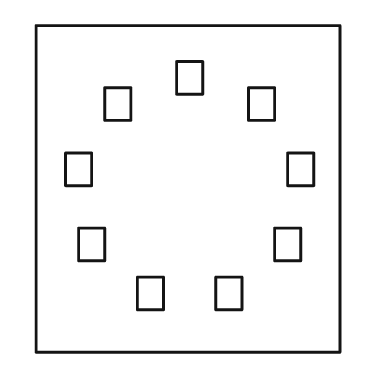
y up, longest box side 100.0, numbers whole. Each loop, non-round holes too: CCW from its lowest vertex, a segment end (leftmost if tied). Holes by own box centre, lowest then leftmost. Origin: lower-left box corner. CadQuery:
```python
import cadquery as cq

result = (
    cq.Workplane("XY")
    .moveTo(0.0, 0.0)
    .lineTo(93.0, 0.0)
    .lineTo(93.0, 100.0)
    .lineTo(0.0, 100.0)
    .close()
    .moveTo(31.0, 13.0)
    .lineTo(39.0, 13.0)
    .lineTo(39.0, 23.0)
    .lineTo(31.0, 23.0)
    .close()
    .moveTo(55.0, 13.0)
    .lineTo(63.0, 13.0)
    .lineTo(63.0, 23.0)
    .lineTo(55.0, 23.0)
    .close()
    .moveTo(13.0, 28.0)
    .lineTo(21.0, 28.0)
    .lineTo(21.0, 38.0)
    .lineTo(13.0, 38.0)
    .close()
    .moveTo(73.0, 28.0)
    .lineTo(81.0, 28.0)
    .lineTo(81.0, 38.0)
    .lineTo(73.0, 38.0)
    .close()
    .moveTo(9.0, 51.0)
    .lineTo(17.0, 51.0)
    .lineTo(17.0, 61.0)
    .lineTo(9.0, 61.0)
    .close()
    .moveTo(77.0, 51.0)
    .lineTo(85.0, 51.0)
    .lineTo(85.0, 61.0)
    .lineTo(77.0, 61.0)
    .close()
    .moveTo(21.0, 71.0)
    .lineTo(29.0, 71.0)
    .lineTo(29.0, 81.0)
    .lineTo(21.0, 81.0)
    .close()
    .moveTo(65.0, 71.0)
    .lineTo(73.0, 71.0)
    .lineTo(73.0, 81.0)
    .lineTo(65.0, 81.0)
    .close()
    .moveTo(43.0, 79.0)
    .lineTo(51.0, 79.0)
    .lineTo(51.0, 89.0)
    .lineTo(43.0, 89.0)
    .close()
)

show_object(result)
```